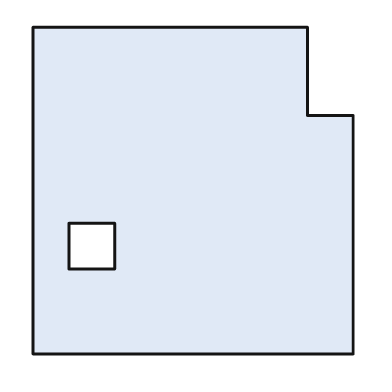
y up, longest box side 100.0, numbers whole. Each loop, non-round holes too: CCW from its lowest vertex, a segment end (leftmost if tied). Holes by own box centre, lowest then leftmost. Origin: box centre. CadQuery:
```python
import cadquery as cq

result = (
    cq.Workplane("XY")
    .moveTo(-49.0, -50.0)
    .lineTo(49.0, -50.0)
    .lineTo(49.0, 23.0)
    .lineTo(35.0, 23.0)
    .lineTo(35.0, 50.0)
    .lineTo(-49.0, 50.0)
    .close()
    .moveTo(-38.0, -24.0)
    .lineTo(-24.0, -24.0)
    .lineTo(-24.0, -10.0)
    .lineTo(-38.0, -10.0)
    .close()
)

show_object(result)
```